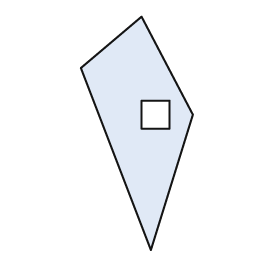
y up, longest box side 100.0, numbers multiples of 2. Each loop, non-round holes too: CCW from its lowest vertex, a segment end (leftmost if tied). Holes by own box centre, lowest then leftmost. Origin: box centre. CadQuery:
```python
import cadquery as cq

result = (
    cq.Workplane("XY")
    .moveTo(6.0, -50.0)
    .lineTo(24.0, 8.0)
    .lineTo(2.0, 50.0)
    .lineTo(-24.0, 28.0)
    .close()
    .moveTo(2.0, 2.0)
    .lineTo(14.0, 2.0)
    .lineTo(14.0, 14.0)
    .lineTo(2.0, 14.0)
    .close()
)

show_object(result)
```